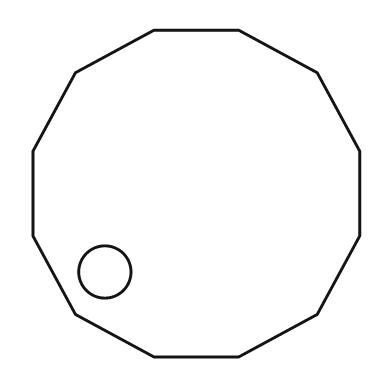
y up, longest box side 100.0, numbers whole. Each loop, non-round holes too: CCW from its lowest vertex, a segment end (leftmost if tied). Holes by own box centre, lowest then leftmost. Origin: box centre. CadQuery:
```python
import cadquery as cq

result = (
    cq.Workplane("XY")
    .moveTo(-13.0, -50.0)
    .lineTo(13.0, -50.0)
    .lineTo(37.0, -37.0)
    .lineTo(50.0, -13.0)
    .lineTo(50.0, 13.0)
    .lineTo(37.0, 37.0)
    .lineTo(13.0, 50.0)
    .lineTo(-13.0, 50.0)
    .lineTo(-37.0, 37.0)
    .lineTo(-50.0, 13.0)
    .lineTo(-50.0, -13.0)
    .lineTo(-37.0, -37.0)
    .close()
    .moveTo(-28.0, -24.0)
    .circle(8.0)
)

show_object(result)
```